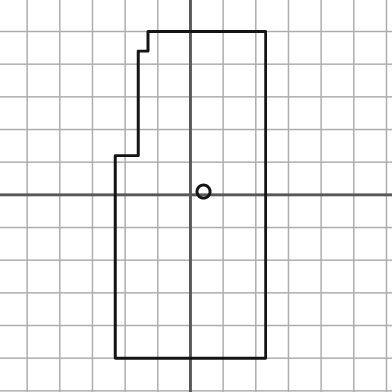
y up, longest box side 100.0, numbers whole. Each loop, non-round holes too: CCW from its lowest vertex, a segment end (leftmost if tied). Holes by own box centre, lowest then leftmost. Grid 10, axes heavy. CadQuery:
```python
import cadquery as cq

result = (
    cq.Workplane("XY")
    .moveTo(-23.0, -50.0)
    .lineTo(23.0, -50.0)
    .lineTo(23.0, 50.0)
    .lineTo(-13.0, 50.0)
    .lineTo(-13.0, 44.0)
    .lineTo(-16.0, 44.0)
    .lineTo(-16.0, 12.0)
    .lineTo(-23.0, 12.0)
    .close()
    .moveTo(4.0, 1.0)
    .circle(2.0)
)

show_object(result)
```